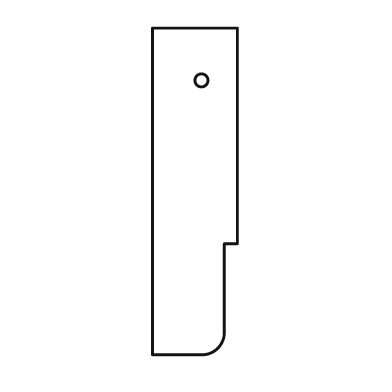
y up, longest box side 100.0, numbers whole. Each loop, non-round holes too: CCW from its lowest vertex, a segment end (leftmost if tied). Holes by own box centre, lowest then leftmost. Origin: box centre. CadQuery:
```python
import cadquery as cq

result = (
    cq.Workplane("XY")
    .moveTo(-13.0, -50.0)
    .lineTo(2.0, -50.0)
    .threePointArc((7.0, -48.0), (9.0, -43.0))
    .lineTo(9.0, -16.0)
    .lineTo(13.0, -16.0)
    .lineTo(13.0, 50.0)
    .lineTo(-13.0, 50.0)
    .close()
    .moveTo(2.0, 34.0)
    .circle(2.0)
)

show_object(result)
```